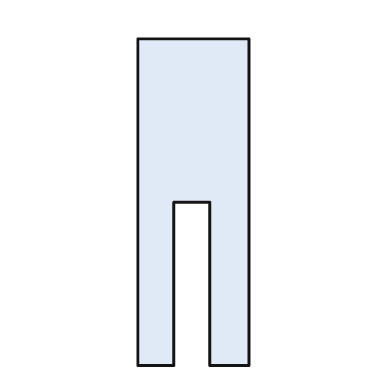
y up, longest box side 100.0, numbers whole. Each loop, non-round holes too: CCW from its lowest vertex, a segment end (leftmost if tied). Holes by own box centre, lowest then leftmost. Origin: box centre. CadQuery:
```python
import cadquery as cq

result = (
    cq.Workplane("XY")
    .moveTo(-17.0, -50.0)
    .lineTo(-6.0, -50.0)
    .lineTo(-6.0, 0.0)
    .lineTo(5.0, 0.0)
    .lineTo(5.0, -50.0)
    .lineTo(17.0, -50.0)
    .lineTo(17.0, 50.0)
    .lineTo(-17.0, 50.0)
    .close()
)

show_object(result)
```